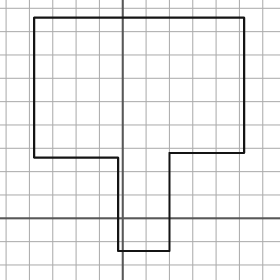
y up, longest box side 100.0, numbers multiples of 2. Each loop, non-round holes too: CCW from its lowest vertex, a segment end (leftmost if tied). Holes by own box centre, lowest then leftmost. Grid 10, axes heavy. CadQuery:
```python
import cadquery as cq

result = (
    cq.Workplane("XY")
    .moveTo(-2.0, -14.0)
    .lineTo(20.0, -14.0)
    .lineTo(20.0, 28.0)
    .lineTo(52.0, 28.0)
    .lineTo(52.0, 86.0)
    .lineTo(-38.0, 86.0)
    .lineTo(-38.0, 26.0)
    .lineTo(-2.0, 26.0)
    .close()
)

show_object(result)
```